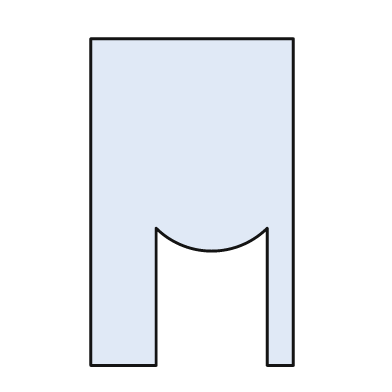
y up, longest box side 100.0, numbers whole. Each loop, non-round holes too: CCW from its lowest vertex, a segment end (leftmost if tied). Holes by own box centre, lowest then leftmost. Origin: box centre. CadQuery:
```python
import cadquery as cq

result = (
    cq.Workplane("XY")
    .moveTo(-31.0, -50.0)
    .lineTo(-11.0, -50.0)
    .lineTo(-11.0, -8.0)
    .threePointArc((6.0, -15.0), (23.0, -8.0))
    .lineTo(23.0, -50.0)
    .lineTo(31.0, -50.0)
    .lineTo(31.0, 50.0)
    .lineTo(-31.0, 50.0)
    .close()
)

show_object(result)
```